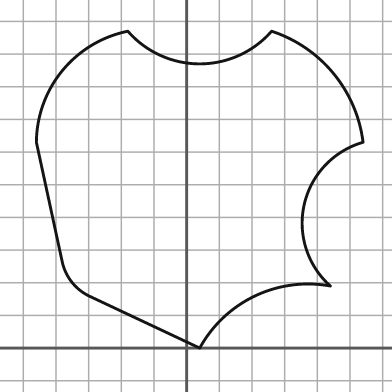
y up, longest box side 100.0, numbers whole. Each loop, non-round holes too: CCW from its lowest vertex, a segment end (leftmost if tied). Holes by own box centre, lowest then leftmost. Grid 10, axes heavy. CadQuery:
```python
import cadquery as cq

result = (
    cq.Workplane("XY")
    .moveTo(4.0, 0.0)
    .threePointArc((21.0, 16.0), (44.0, 19.0))
    .threePointArc((36.0, 44.0), (54.0, 63.0))
    .threePointArc((45.0, 84.0), (26.0, 97.0))
    .threePointArc((4.0, 87.0), (-18.0, 97.0))
    .threePointArc((-38.0, 85.0), (-46.0, 63.0))
    .lineTo(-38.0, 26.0)
    .threePointArc((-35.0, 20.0), (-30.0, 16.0))
    .close()
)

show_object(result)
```